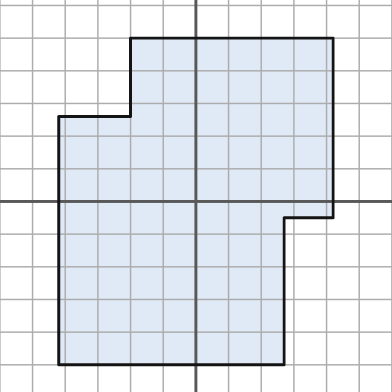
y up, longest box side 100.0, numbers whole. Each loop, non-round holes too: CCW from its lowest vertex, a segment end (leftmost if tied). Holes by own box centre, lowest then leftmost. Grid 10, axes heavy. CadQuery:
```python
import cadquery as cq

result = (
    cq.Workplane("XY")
    .moveTo(-42.0, -50.0)
    .lineTo(27.0, -50.0)
    .lineTo(27.0, -5.0)
    .lineTo(42.0, -5.0)
    .lineTo(42.0, 50.0)
    .lineTo(-20.0, 50.0)
    .lineTo(-20.0, 26.0)
    .lineTo(-42.0, 26.0)
    .close()
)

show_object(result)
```